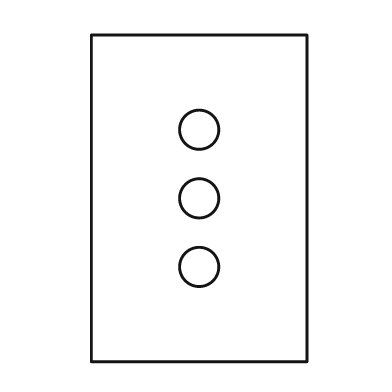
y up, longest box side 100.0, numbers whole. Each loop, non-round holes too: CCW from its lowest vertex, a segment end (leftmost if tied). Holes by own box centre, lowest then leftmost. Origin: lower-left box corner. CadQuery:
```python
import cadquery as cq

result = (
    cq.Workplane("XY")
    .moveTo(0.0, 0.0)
    .lineTo(66.0, 0.0)
    .lineTo(66.0, 100.0)
    .lineTo(0.0, 100.0)
    .close()
    .moveTo(33.0, 29.0)
    .circle(6.0)
    .moveTo(33.0, 50.0)
    .circle(6.0)
    .moveTo(33.0, 71.0)
    .circle(6.0)
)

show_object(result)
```